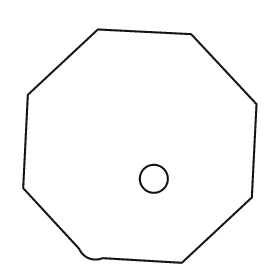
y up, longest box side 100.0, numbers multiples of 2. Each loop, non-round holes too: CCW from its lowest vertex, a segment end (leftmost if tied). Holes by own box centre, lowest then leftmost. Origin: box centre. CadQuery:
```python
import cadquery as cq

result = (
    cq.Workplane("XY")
    .moveTo(18.0, -50.0)
    .lineTo(48.0, -22.0)
    .lineTo(50.0, 18.0)
    .lineTo(22.0, 48.0)
    .lineTo(-18.0, 50.0)
    .lineTo(-48.0, 22.0)
    .lineTo(-50.0, -18.0)
    .lineTo(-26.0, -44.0)
    .threePointArc((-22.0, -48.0), (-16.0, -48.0))
    .close()
    .moveTo(6.0, -14.0)
    .circle(6.0)
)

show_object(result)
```